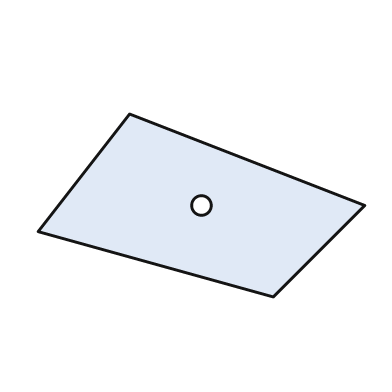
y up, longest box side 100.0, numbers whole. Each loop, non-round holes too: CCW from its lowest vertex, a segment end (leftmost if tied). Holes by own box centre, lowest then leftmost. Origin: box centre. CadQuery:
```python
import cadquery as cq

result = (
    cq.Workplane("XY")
    .moveTo(22.0, -28.0)
    .lineTo(50.0, 0.0)
    .lineTo(-22.0, 28.0)
    .lineTo(-50.0, -8.0)
    .close()
    .moveTo(0.0, 0.0)
    .circle(3.0)
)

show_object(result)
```